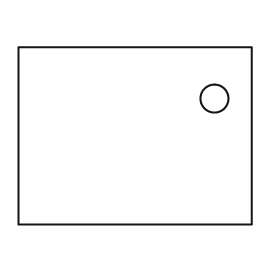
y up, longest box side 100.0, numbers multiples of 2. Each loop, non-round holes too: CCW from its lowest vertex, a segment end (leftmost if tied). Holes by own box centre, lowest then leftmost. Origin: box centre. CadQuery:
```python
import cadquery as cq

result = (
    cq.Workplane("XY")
    .moveTo(-50.0, -38.0)
    .lineTo(50.0, -38.0)
    .lineTo(50.0, 38.0)
    .lineTo(-50.0, 38.0)
    .close()
    .moveTo(34.0, 16.0)
    .circle(6.0)
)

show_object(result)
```